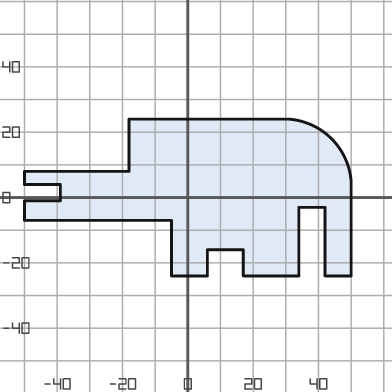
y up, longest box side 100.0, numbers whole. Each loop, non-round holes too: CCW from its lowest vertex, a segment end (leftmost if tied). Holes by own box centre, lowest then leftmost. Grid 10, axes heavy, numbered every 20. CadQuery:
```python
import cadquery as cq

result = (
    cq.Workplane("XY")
    .moveTo(-5.0, -24.0)
    .lineTo(6.0, -24.0)
    .lineTo(6.0, -16.0)
    .lineTo(17.0, -16.0)
    .lineTo(17.0, -24.0)
    .lineTo(34.0, -24.0)
    .lineTo(34.0, -3.0)
    .lineTo(42.0, -3.0)
    .lineTo(42.0, -24.0)
    .lineTo(50.0, -24.0)
    .lineTo(50.0, 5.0)
    .threePointArc((44.0, 18.0), (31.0, 24.0))
    .lineTo(-18.0, 24.0)
    .lineTo(-18.0, 8.0)
    .lineTo(-50.0, 8.0)
    .lineTo(-50.0, 4.0)
    .lineTo(-39.0, 4.0)
    .lineTo(-39.0, -1.0)
    .lineTo(-50.0, -1.0)
    .lineTo(-50.0, -7.0)
    .lineTo(-5.0, -7.0)
    .close()
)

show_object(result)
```